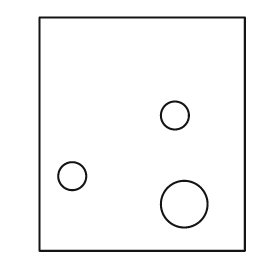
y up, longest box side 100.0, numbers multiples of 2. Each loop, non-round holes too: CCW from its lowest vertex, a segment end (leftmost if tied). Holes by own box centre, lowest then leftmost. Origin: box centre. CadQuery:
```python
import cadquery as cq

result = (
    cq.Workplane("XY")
    .moveTo(-44.0, -50.0)
    .lineTo(44.0, -50.0)
    .lineTo(44.0, 50.0)
    .lineTo(-44.0, 50.0)
    .close()
    .moveTo(18.0, -30.0)
    .circle(10.0)
    .moveTo(-30.0, -18.0)
    .circle(6.0)
    .moveTo(14.0, 8.0)
    .circle(6.0)
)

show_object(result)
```